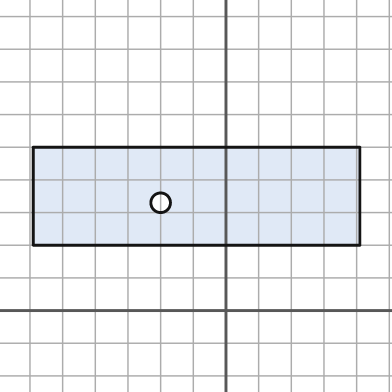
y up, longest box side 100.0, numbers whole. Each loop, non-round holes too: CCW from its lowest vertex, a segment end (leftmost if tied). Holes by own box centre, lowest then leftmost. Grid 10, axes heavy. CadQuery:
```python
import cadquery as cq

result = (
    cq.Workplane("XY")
    .moveTo(-59.0, 20.0)
    .lineTo(41.0, 20.0)
    .lineTo(41.0, 50.0)
    .lineTo(-59.0, 50.0)
    .close()
    .moveTo(-20.0, 33.0)
    .circle(3.0)
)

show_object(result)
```